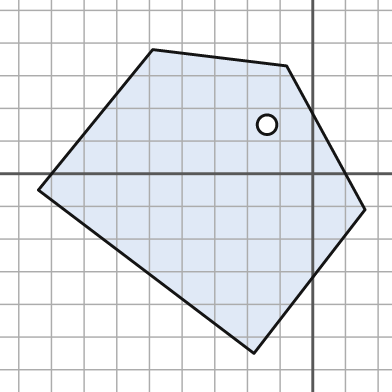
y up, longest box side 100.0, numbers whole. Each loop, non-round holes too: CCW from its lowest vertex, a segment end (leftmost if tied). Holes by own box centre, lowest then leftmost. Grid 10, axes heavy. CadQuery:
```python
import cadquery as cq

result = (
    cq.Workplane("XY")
    .moveTo(-18.0, -55.0)
    .lineTo(16.0, -11.0)
    .lineTo(-8.0, 33.0)
    .lineTo(-49.0, 38.0)
    .lineTo(-84.0, -5.0)
    .close()
    .moveTo(-14.0, 15.0)
    .circle(3.0)
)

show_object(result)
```